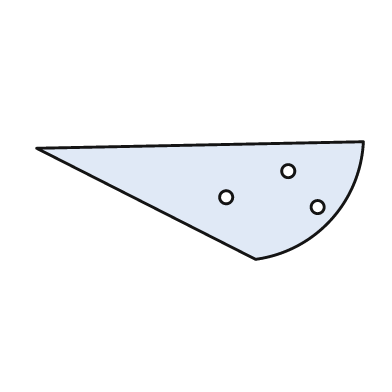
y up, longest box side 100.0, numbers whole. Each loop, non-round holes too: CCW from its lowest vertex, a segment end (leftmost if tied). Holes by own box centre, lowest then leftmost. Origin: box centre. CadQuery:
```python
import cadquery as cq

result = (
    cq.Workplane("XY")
    .moveTo(17.0, -18.0)
    .threePointArc((40.0, -6.0), (50.0, 18.0))
    .lineTo(-50.0, 16.0)
    .close()
    .moveTo(36.0, -2.0)
    .circle(2.0)
    .moveTo(8.0, 1.0)
    .circle(2.0)
    .moveTo(27.0, 9.0)
    .circle(2.0)
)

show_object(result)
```